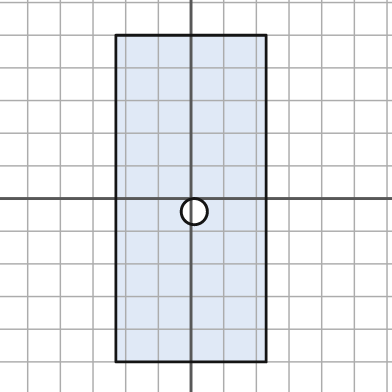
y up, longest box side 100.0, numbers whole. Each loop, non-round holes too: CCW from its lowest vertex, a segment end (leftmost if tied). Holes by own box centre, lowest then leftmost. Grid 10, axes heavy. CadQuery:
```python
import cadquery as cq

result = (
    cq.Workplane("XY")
    .moveTo(-23.0, -50.0)
    .lineTo(23.0, -50.0)
    .lineTo(23.0, 50.0)
    .lineTo(-23.0, 50.0)
    .close()
    .moveTo(1.0, -4.0)
    .circle(4.0)
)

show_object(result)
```